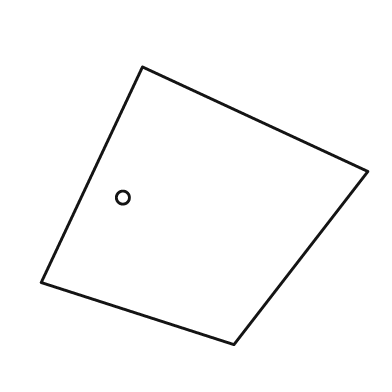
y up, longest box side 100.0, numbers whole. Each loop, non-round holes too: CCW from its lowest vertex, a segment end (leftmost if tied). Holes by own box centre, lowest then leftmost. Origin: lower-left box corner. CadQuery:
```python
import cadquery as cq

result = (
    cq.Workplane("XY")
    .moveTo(59.0, 0.0)
    .lineTo(100.0, 53.0)
    .lineTo(31.0, 85.0)
    .lineTo(0.0, 19.0)
    .close()
    .moveTo(25.0, 45.0)
    .circle(2.0)
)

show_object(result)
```